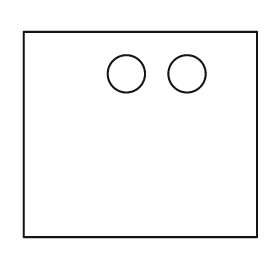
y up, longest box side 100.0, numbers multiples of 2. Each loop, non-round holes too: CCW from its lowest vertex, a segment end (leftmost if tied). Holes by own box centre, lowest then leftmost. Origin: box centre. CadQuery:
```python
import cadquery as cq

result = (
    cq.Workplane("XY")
    .moveTo(-50.0, -44.0)
    .lineTo(50.0, -44.0)
    .lineTo(50.0, 44.0)
    .lineTo(-50.0, 44.0)
    .close()
    .moveTo(-6.0, 26.0)
    .circle(8.0)
    .moveTo(20.0, 26.0)
    .circle(8.0)
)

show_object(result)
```